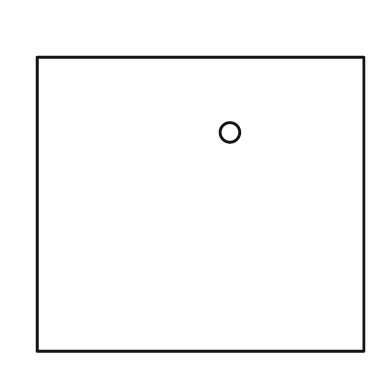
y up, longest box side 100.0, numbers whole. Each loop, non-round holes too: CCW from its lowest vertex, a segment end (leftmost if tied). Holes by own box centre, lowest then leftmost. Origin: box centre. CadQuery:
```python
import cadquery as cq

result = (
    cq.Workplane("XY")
    .moveTo(-50.0, -45.0)
    .lineTo(50.0, -45.0)
    .lineTo(50.0, 45.0)
    .lineTo(-50.0, 45.0)
    .close()
    .moveTo(9.0, 22.0)
    .circle(3.0)
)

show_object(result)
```